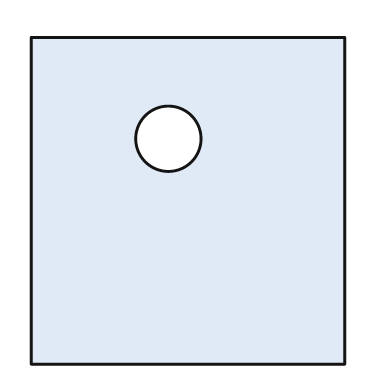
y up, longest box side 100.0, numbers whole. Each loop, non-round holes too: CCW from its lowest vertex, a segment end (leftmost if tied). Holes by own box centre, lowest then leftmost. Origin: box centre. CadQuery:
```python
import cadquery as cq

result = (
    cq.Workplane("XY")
    .moveTo(-48.0, -50.0)
    .lineTo(48.0, -50.0)
    .lineTo(48.0, 50.0)
    .lineTo(-48.0, 50.0)
    .close()
    .moveTo(-6.0, 19.0)
    .circle(10.0)
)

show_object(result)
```